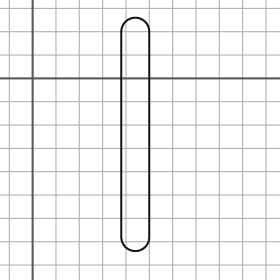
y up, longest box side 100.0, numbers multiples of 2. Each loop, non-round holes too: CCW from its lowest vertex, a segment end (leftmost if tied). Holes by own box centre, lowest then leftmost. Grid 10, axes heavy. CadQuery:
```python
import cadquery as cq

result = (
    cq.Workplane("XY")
    .moveTo(38.0, -68.0)
    .threePointArc((44.0, -74.0), (50.0, -68.0))
    .lineTo(50.0, 20.0)
    .threePointArc((44.0, 26.0), (38.0, 20.0))
    .close()
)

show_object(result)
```